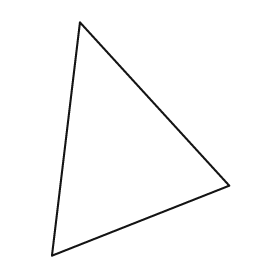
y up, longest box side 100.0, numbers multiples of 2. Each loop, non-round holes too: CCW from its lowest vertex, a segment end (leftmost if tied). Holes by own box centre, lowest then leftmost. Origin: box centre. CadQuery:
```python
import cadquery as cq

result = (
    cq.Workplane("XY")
    .moveTo(-38.0, -50.0)
    .lineTo(38.0, -20.0)
    .lineTo(-26.0, 50.0)
    .close()
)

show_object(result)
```